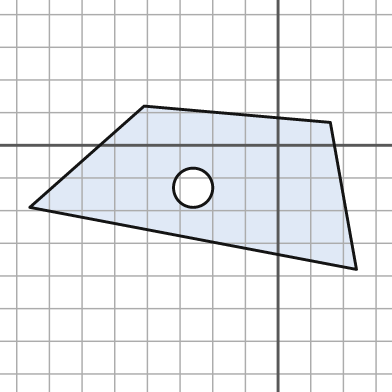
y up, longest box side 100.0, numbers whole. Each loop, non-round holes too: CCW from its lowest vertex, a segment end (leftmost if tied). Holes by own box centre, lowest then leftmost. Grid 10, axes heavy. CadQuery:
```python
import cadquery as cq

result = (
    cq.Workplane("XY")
    .moveTo(24.0, -38.0)
    .lineTo(16.0, 7.0)
    .lineTo(-41.0, 12.0)
    .lineTo(-76.0, -19.0)
    .close()
    .moveTo(-26.0, -13.0)
    .circle(6.0)
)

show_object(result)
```